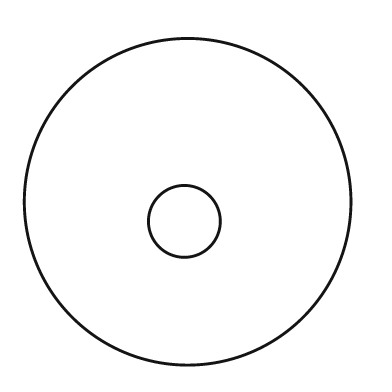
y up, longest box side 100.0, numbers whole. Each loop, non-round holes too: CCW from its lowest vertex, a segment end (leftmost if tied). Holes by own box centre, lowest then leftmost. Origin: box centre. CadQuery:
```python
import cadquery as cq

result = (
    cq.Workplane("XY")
    .moveTo(0.0, 0.0)
    .circle(50.0)
    .moveTo(-1.0, -6.0)
    .circle(11.0)
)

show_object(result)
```